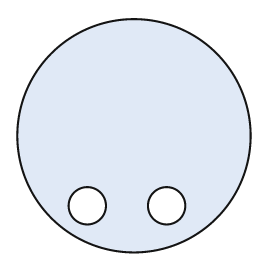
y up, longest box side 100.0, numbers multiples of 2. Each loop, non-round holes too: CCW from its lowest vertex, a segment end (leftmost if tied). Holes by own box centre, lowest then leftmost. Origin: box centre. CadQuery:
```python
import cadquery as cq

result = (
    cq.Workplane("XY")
    .moveTo(0.0, 0.0)
    .circle(50.0)
    .moveTo(-20.0, -30.0)
    .circle(8.0)
    .moveTo(14.0, -30.0)
    .circle(8.0)
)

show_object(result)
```